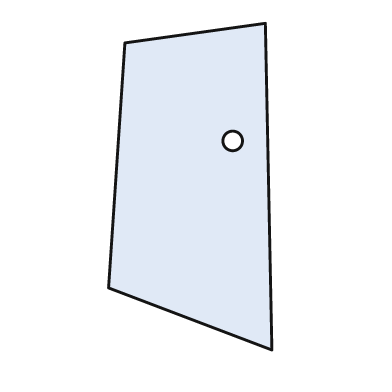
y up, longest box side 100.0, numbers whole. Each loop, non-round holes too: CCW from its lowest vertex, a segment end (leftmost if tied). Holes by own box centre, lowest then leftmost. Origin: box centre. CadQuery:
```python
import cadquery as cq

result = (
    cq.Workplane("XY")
    .moveTo(25.0, -50.0)
    .lineTo(23.0, 50.0)
    .lineTo(-20.0, 44.0)
    .lineTo(-25.0, -31.0)
    .close()
    .moveTo(13.0, 14.0)
    .circle(3.0)
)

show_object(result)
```